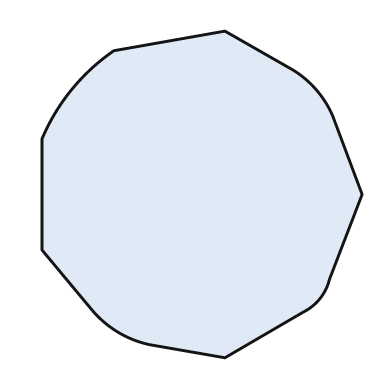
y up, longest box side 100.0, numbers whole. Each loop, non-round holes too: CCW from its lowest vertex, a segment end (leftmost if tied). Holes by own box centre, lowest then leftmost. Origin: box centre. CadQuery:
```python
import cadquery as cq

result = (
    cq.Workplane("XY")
    .moveTo(7.0, -50.0)
    .lineTo(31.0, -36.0)
    .threePointArc((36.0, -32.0), (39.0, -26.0))
    .lineTo(49.0, 0.0)
    .lineTo(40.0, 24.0)
    .threePointArc((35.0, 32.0), (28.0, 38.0))
    .lineTo(7.0, 50.0)
    .lineTo(-27.0, 44.0)
    .threePointArc((-40.0, 32.0), (-49.0, 17.0))
    .lineTo(-49.0, -17.0)
    .lineTo(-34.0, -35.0)
    .threePointArc((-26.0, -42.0), (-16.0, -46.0))
    .close()
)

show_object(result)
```